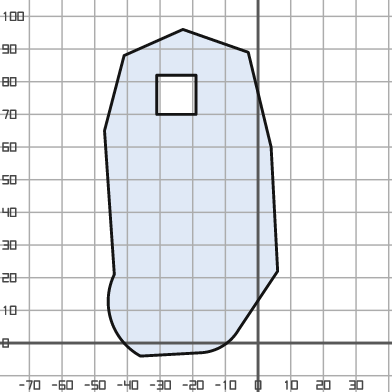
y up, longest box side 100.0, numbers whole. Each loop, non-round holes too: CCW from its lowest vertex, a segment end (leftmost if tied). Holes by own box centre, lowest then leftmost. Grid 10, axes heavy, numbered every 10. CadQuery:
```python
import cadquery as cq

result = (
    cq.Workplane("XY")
    .moveTo(-36.0, -4.0)
    .lineTo(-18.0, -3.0)
    .threePointArc((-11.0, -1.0), (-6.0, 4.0))
    .lineTo(6.0, 22.0)
    .lineTo(4.0, 60.0)
    .lineTo(-3.0, 89.0)
    .lineTo(-23.0, 96.0)
    .lineTo(-41.0, 88.0)
    .lineTo(-47.0, 65.0)
    .lineTo(-44.0, 21.0)
    .threePointArc((-45.0, 7.0), (-36.0, -4.0))
    .close()
    .moveTo(-31.0, 70.0)
    .lineTo(-19.0, 70.0)
    .lineTo(-19.0, 82.0)
    .lineTo(-31.0, 82.0)
    .close()
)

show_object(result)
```